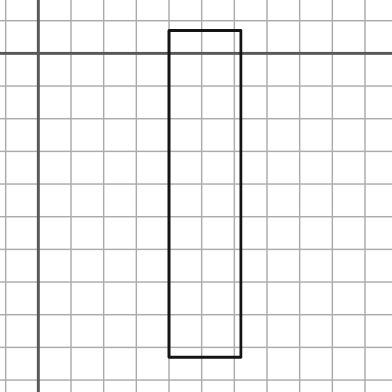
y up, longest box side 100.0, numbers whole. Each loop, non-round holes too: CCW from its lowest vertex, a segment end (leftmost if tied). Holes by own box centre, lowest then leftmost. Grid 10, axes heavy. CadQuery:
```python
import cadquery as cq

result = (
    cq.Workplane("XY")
    .moveTo(40.0, -93.0)
    .lineTo(62.0, -93.0)
    .lineTo(62.0, 7.0)
    .lineTo(40.0, 7.0)
    .close()
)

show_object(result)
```